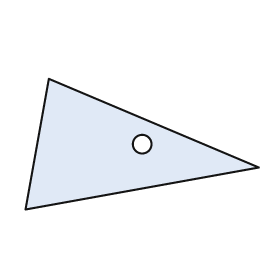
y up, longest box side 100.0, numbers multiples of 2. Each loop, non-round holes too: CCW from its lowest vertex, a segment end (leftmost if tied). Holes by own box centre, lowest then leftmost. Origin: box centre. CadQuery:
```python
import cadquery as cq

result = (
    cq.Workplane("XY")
    .moveTo(-50.0, -28.0)
    .lineTo(50.0, -10.0)
    .lineTo(-40.0, 28.0)
    .close()
    .moveTo(0.0, 0.0)
    .circle(4.0)
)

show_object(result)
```